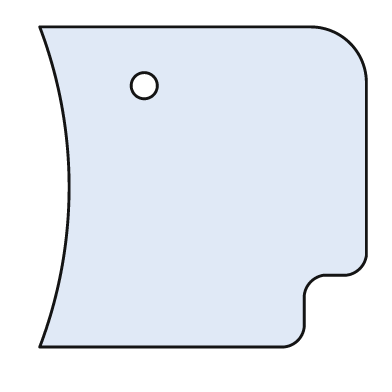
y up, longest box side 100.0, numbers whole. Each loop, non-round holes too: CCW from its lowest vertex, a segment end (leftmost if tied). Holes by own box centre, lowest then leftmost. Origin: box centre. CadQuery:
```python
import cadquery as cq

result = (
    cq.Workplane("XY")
    .moveTo(-50.0, -49.0)
    .lineTo(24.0, -49.0)
    .threePointArc((29.0, -47.0), (31.0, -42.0))
    .lineTo(31.0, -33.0)
    .threePointArc((33.0, -29.0), (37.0, -27.0))
    .lineTo(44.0, -27.0)
    .threePointArc((48.0, -25.0), (50.0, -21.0))
    .lineTo(50.0, 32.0)
    .threePointArc((45.0, 44.0), (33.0, 49.0))
    .lineTo(-50.0, 49.0)
    .threePointArc((-41.0, 0.0), (-50.0, -49.0))
    .close()
    .moveTo(-18.0, 31.0)
    .circle(4.0)
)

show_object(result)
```